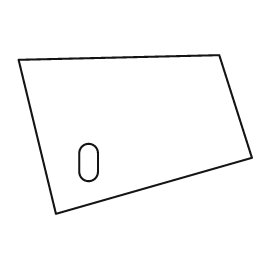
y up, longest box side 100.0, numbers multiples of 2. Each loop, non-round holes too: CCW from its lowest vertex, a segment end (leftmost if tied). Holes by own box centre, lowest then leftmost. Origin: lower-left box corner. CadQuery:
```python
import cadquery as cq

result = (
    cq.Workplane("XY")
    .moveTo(16.0, 0.0)
    .lineTo(100.0, 24.0)
    .lineTo(86.0, 68.0)
    .lineTo(0.0, 66.0)
    .close()
    .moveTo(26.0, 18.0)
    .threePointArc((30.0, 14.0), (34.0, 18.0))
    .lineTo(34.0, 26.0)
    .threePointArc((30.0, 30.0), (26.0, 26.0))
    .close()
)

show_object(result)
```